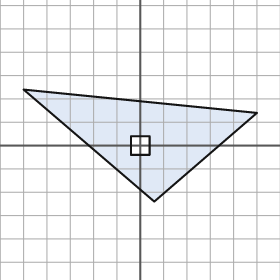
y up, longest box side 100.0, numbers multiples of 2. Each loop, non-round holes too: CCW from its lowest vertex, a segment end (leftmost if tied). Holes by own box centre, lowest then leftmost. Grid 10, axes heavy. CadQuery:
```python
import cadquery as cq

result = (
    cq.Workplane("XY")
    .moveTo(6.0, -24.0)
    .lineTo(50.0, 14.0)
    .lineTo(-50.0, 24.0)
    .close()
    .moveTo(-4.0, -4.0)
    .lineTo(4.0, -4.0)
    .lineTo(4.0, 4.0)
    .lineTo(-4.0, 4.0)
    .close()
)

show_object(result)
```